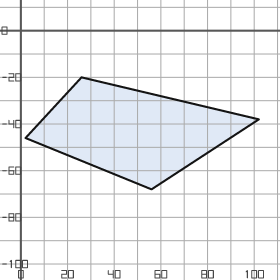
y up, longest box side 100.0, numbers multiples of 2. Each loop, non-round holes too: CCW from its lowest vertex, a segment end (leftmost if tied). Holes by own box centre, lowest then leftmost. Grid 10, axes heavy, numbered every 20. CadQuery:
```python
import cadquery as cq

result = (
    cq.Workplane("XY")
    .moveTo(56.0, -68.0)
    .lineTo(102.0, -38.0)
    .lineTo(26.0, -20.0)
    .lineTo(2.0, -46.0)
    .close()
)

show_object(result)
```